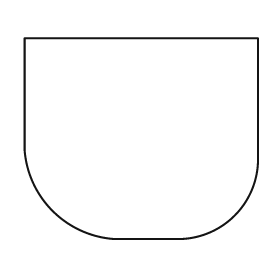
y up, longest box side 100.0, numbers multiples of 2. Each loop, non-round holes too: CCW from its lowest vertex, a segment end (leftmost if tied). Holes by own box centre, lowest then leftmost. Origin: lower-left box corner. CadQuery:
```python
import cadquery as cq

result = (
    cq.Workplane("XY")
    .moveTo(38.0, 0.0)
    .lineTo(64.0, 0.0)
    .threePointArc((90.0, 10.0), (100.0, 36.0))
    .lineTo(100.0, 86.0)
    .lineTo(0.0, 86.0)
    .lineTo(0.0, 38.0)
    .threePointArc((12.0, 12.0), (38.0, 0.0))
    .close()
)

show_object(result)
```